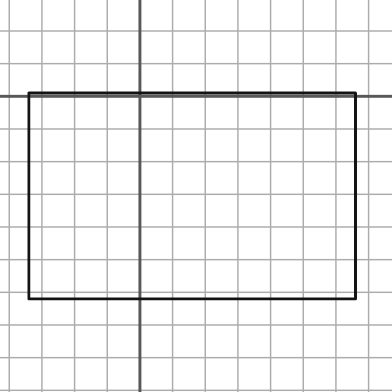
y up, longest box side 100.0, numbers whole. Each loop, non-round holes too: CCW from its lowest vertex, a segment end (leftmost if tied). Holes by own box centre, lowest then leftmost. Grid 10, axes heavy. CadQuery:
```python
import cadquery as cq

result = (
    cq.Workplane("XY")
    .moveTo(-34.0, -62.0)
    .lineTo(66.0, -62.0)
    .lineTo(66.0, 1.0)
    .lineTo(-34.0, 1.0)
    .close()
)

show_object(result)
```